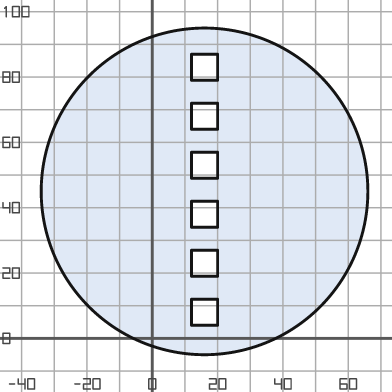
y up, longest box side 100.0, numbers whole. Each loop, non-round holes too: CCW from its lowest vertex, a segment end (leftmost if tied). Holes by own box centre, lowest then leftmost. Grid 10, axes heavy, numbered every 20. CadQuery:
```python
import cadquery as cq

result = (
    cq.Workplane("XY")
    .moveTo(16.0, 45.0)
    .circle(50.0)
    .moveTo(12.0, 4.0)
    .lineTo(20.0, 4.0)
    .lineTo(20.0, 12.0)
    .lineTo(12.0, 12.0)
    .close()
    .moveTo(12.0, 19.0)
    .lineTo(20.0, 19.0)
    .lineTo(20.0, 27.0)
    .lineTo(12.0, 27.0)
    .close()
    .moveTo(12.0, 34.0)
    .lineTo(20.0, 34.0)
    .lineTo(20.0, 42.0)
    .lineTo(12.0, 42.0)
    .close()
    .moveTo(12.0, 49.0)
    .lineTo(20.0, 49.0)
    .lineTo(20.0, 57.0)
    .lineTo(12.0, 57.0)
    .close()
    .moveTo(12.0, 64.0)
    .lineTo(20.0, 64.0)
    .lineTo(20.0, 72.0)
    .lineTo(12.0, 72.0)
    .close()
    .moveTo(12.0, 79.0)
    .lineTo(20.0, 79.0)
    .lineTo(20.0, 87.0)
    .lineTo(12.0, 87.0)
    .close()
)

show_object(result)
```